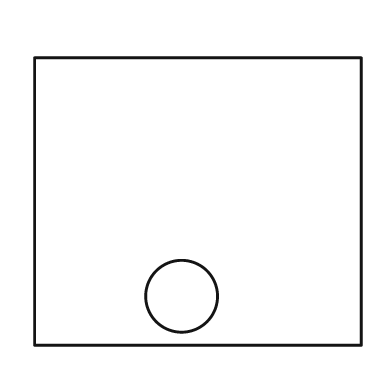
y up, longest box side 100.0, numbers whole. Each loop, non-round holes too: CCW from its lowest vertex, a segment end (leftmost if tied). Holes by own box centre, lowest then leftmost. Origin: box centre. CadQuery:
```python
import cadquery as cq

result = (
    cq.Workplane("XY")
    .moveTo(-50.0, -44.0)
    .lineTo(50.0, -44.0)
    .lineTo(50.0, 44.0)
    .lineTo(-50.0, 44.0)
    .close()
    .moveTo(-5.0, -29.0)
    .circle(11.0)
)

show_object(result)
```